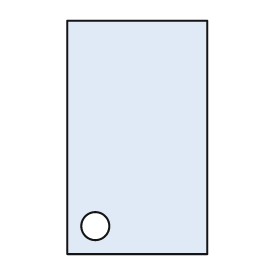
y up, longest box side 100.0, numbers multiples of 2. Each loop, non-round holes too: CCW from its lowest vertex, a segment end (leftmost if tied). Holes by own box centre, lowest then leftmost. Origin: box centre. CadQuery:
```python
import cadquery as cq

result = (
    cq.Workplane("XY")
    .moveTo(-30.0, -50.0)
    .lineTo(30.0, -50.0)
    .lineTo(30.0, 50.0)
    .lineTo(-30.0, 50.0)
    .close()
    .moveTo(-18.0, -38.0)
    .circle(6.0)
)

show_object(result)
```